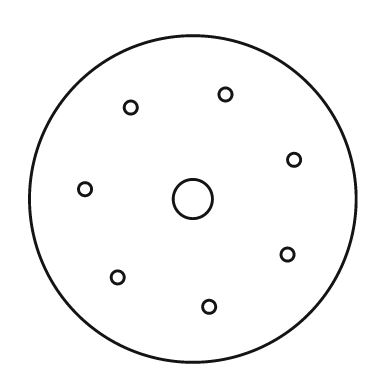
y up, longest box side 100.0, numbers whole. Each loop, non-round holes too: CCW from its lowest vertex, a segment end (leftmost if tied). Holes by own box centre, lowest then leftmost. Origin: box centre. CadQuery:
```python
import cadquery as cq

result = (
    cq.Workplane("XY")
    .moveTo(0.0, 0.0)
    .circle(50.0)
    .moveTo(5.0, -33.0)
    .circle(2.0)
    .moveTo(-23.0, -24.0)
    .circle(2.0)
    .moveTo(29.0, -17.0)
    .circle(2.0)
    .moveTo(0.0, 0.0)
    .circle(6.0)
    .moveTo(-33.0, 3.0)
    .circle(2.0)
    .moveTo(31.0, 12.0)
    .circle(2.0)
    .moveTo(-19.0, 28.0)
    .circle(2.0)
    .moveTo(10.0, 32.0)
    .circle(2.0)
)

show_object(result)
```